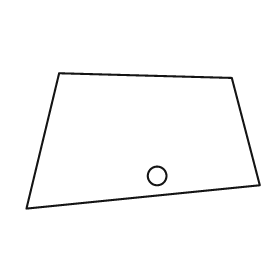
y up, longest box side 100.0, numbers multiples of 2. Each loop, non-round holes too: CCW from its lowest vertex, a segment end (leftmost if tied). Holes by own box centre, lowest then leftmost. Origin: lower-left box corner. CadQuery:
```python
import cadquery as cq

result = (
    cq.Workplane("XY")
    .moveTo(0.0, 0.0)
    .lineTo(100.0, 10.0)
    .lineTo(88.0, 56.0)
    .lineTo(14.0, 58.0)
    .close()
    .moveTo(56.0, 14.0)
    .circle(4.0)
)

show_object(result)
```